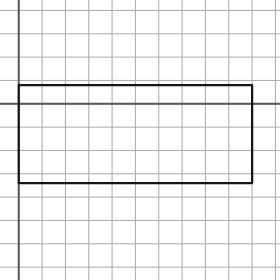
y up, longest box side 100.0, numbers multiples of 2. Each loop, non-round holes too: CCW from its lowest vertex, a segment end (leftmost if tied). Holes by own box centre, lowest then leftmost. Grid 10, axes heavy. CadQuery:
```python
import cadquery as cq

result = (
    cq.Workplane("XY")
    .moveTo(0.0, -34.0)
    .lineTo(100.0, -34.0)
    .lineTo(100.0, 8.0)
    .lineTo(0.0, 8.0)
    .close()
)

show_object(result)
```